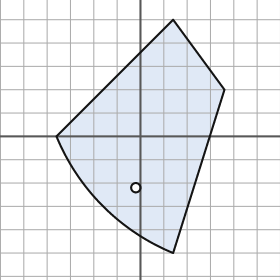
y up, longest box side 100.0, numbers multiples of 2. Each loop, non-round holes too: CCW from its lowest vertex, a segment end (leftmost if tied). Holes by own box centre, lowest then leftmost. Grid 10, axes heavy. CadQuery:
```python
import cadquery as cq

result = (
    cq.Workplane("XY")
    .moveTo(14.0, -50.0)
    .lineTo(36.0, 20.0)
    .lineTo(14.0, 50.0)
    .lineTo(-36.0, 0.0)
    .threePointArc((-16.0, -30.0), (14.0, -50.0))
    .close()
    .moveTo(-2.0, -22.0)
    .circle(2.0)
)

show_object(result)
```